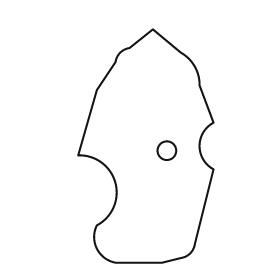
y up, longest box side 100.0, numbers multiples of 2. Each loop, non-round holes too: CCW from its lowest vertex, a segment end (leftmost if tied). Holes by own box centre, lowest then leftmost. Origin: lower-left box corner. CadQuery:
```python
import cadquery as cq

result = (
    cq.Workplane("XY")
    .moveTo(16.0, 0.0)
    .lineTo(36.0, 0.0)
    .lineTo(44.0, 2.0)
    .threePointArc((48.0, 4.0), (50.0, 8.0))
    .lineTo(58.0, 40.0)
    .threePointArc((52.0, 50.0), (58.0, 60.0))
    .lineTo(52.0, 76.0)
    .threePointArc((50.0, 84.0), (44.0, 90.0))
    .lineTo(32.0, 100.0)
    .lineTo(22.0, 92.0)
    .threePointArc((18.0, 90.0), (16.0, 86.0))
    .lineTo(8.0, 74.0)
    .lineTo(0.0, 46.0)
    .threePointArc((16.0, 34.0), (8.0, 16.0))
    .threePointArc((8.0, 6.0), (16.0, 0.0))
    .close()
    .moveTo(38.0, 48.0)
    .circle(4.0)
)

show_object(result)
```